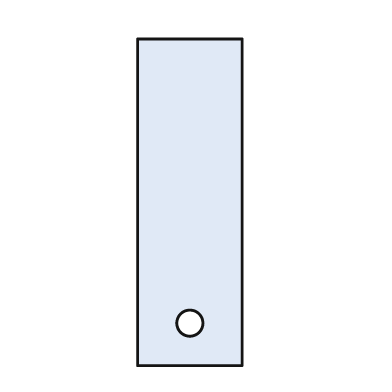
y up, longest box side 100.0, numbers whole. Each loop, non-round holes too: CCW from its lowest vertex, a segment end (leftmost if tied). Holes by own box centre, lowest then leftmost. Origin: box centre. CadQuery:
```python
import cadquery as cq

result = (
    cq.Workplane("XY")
    .moveTo(-16.0, -50.0)
    .lineTo(16.0, -50.0)
    .lineTo(16.0, 50.0)
    .lineTo(-16.0, 50.0)
    .close()
    .moveTo(0.0, -37.0)
    .circle(4.0)
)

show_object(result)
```